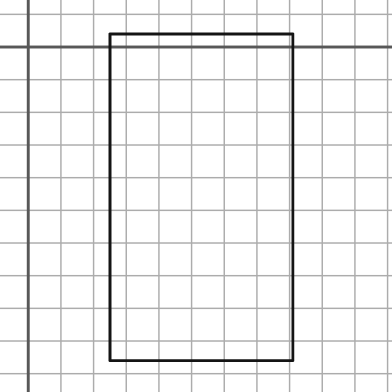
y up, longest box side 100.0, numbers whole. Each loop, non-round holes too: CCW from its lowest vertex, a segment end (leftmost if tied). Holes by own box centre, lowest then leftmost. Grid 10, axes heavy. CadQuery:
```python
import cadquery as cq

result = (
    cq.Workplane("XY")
    .moveTo(25.0, -96.0)
    .lineTo(81.0, -96.0)
    .lineTo(81.0, 4.0)
    .lineTo(25.0, 4.0)
    .close()
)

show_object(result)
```